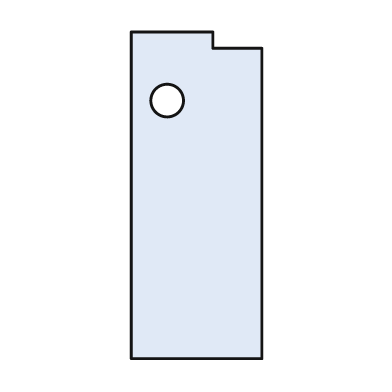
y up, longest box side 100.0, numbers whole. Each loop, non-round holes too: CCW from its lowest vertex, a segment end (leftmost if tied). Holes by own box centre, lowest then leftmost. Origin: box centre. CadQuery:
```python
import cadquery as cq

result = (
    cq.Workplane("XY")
    .moveTo(-20.0, -50.0)
    .lineTo(20.0, -50.0)
    .lineTo(20.0, 45.0)
    .lineTo(5.0, 45.0)
    .lineTo(5.0, 50.0)
    .lineTo(-20.0, 50.0)
    .close()
    .moveTo(-9.0, 29.0)
    .circle(5.0)
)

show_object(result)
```